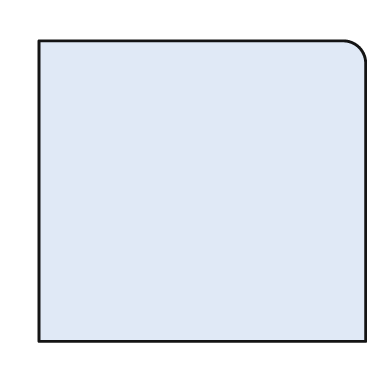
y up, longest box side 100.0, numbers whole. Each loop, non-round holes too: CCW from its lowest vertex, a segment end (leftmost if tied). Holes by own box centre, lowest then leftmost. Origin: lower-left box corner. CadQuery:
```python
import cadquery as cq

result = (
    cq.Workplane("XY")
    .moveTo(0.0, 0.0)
    .lineTo(100.0, 0.0)
    .lineTo(100.0, 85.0)
    .threePointArc((98.0, 90.0), (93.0, 92.0))
    .lineTo(0.0, 92.0)
    .close()
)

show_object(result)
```